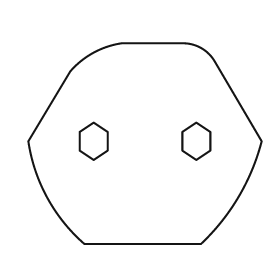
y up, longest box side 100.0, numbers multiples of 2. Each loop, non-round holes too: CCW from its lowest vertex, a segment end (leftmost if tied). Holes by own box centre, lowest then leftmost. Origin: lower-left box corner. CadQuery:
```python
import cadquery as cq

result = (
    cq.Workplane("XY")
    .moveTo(24.0, 0.0)
    .lineTo(74.0, 0.0)
    .threePointArc((90.0, 20.0), (100.0, 44.0))
    .lineTo(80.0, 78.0)
    .threePointArc((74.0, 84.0), (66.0, 86.0))
    .lineTo(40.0, 86.0)
    .threePointArc((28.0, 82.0), (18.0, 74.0))
    .lineTo(0.0, 44.0)
    .threePointArc((8.0, 20.0), (24.0, 0.0))
    .close()
    .moveTo(28.0, 36.0)
    .lineTo(34.0, 40.0)
    .lineTo(34.0, 48.0)
    .lineTo(28.0, 52.0)
    .lineTo(22.0, 48.0)
    .lineTo(22.0, 40.0)
    .close()
    .moveTo(72.0, 36.0)
    .lineTo(78.0, 40.0)
    .lineTo(78.0, 48.0)
    .lineTo(72.0, 52.0)
    .lineTo(66.0, 48.0)
    .lineTo(66.0, 40.0)
    .close()
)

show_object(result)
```